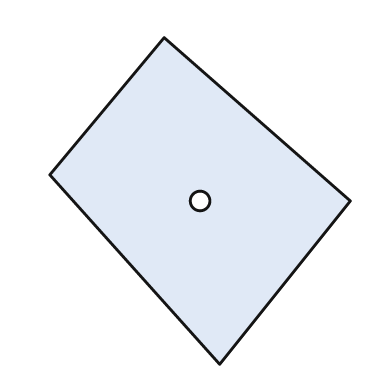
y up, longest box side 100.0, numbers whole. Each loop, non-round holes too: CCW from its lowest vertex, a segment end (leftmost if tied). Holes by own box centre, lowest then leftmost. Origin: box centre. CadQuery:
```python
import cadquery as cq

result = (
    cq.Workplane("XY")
    .moveTo(6.0, -50.0)
    .lineTo(46.0, 0.0)
    .lineTo(-11.0, 50.0)
    .lineTo(-46.0, 8.0)
    .close()
    .moveTo(0.0, 0.0)
    .circle(3.0)
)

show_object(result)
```